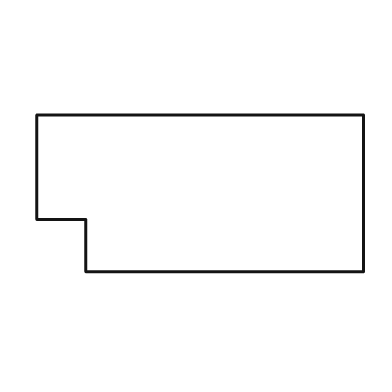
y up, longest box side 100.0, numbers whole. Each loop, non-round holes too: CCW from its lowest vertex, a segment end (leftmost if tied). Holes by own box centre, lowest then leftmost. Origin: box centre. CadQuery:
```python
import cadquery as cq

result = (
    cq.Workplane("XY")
    .moveTo(-35.0, -24.0)
    .lineTo(50.0, -24.0)
    .lineTo(50.0, 24.0)
    .lineTo(-50.0, 24.0)
    .lineTo(-50.0, -8.0)
    .lineTo(-35.0, -8.0)
    .close()
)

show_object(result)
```